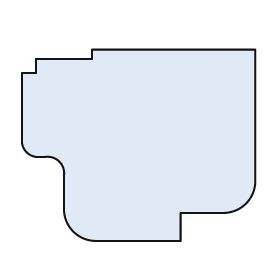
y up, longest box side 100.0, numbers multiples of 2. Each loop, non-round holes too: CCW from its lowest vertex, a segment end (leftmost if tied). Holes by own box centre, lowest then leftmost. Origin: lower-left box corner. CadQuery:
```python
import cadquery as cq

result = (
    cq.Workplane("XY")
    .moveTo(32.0, 0.0)
    .lineTo(68.0, 0.0)
    .lineTo(68.0, 12.0)
    .lineTo(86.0, 12.0)
    .threePointArc((96.0, 16.0), (100.0, 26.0))
    .lineTo(100.0, 82.0)
    .lineTo(30.0, 82.0)
    .lineTo(30.0, 78.0)
    .lineTo(6.0, 78.0)
    .lineTo(6.0, 72.0)
    .lineTo(0.0, 72.0)
    .lineTo(0.0, 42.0)
    .threePointArc((2.0, 38.0), (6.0, 36.0))
    .lineTo(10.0, 36.0)
    .threePointArc((16.0, 34.0), (18.0, 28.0))
    .lineTo(18.0, 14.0)
    .threePointArc((22.0, 4.0), (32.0, 0.0))
    .close()
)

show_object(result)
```